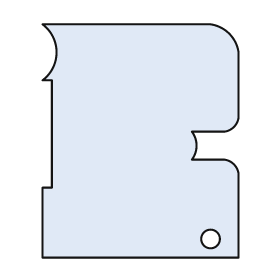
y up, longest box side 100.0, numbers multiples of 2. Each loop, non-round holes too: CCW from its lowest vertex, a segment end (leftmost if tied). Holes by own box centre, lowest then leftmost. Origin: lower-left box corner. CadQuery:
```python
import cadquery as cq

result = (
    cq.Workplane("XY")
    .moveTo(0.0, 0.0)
    .lineTo(84.0, 0.0)
    .lineTo(84.0, 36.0)
    .threePointArc((82.0, 40.0), (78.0, 42.0))
    .lineTo(64.0, 42.0)
    .threePointArc((66.0, 48.0), (64.0, 54.0))
    .lineTo(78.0, 54.0)
    .threePointArc((82.0, 56.0), (84.0, 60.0))
    .lineTo(84.0, 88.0)
    .threePointArc((80.0, 96.0), (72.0, 100.0))
    .lineTo(0.0, 100.0)
    .threePointArc((6.0, 88.0), (0.0, 76.0))
    .lineTo(4.0, 76.0)
    .lineTo(4.0, 30.0)
    .lineTo(0.0, 30.0)
    .close()
    .moveTo(72.0, 8.0)
    .circle(4.0)
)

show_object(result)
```